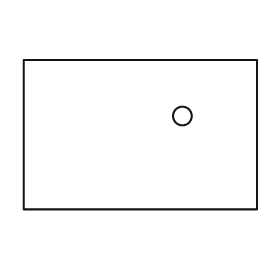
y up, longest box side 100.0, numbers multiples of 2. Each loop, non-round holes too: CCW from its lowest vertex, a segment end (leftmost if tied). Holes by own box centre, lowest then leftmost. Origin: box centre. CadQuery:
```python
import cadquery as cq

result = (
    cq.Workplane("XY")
    .moveTo(-50.0, -32.0)
    .lineTo(50.0, -32.0)
    .lineTo(50.0, 32.0)
    .lineTo(-50.0, 32.0)
    .close()
    .moveTo(18.0, 8.0)
    .circle(4.0)
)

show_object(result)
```